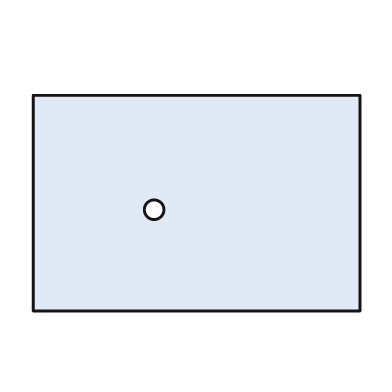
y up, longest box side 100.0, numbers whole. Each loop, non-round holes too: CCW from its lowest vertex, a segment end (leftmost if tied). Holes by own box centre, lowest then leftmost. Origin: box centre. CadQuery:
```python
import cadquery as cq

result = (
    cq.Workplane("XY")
    .moveTo(-50.0, -33.0)
    .lineTo(50.0, -33.0)
    .lineTo(50.0, 33.0)
    .lineTo(-50.0, 33.0)
    .close()
    .moveTo(-13.0, -2.0)
    .circle(3.0)
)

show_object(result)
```